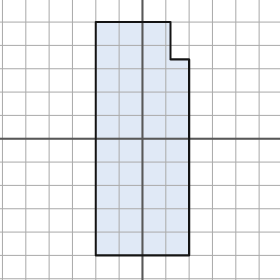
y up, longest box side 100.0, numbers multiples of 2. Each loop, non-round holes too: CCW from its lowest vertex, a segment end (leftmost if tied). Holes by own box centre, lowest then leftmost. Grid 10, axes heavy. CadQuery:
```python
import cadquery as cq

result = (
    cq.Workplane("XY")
    .moveTo(-20.0, -50.0)
    .lineTo(20.0, -50.0)
    .lineTo(20.0, 34.0)
    .lineTo(12.0, 34.0)
    .lineTo(12.0, 50.0)
    .lineTo(-20.0, 50.0)
    .close()
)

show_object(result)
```